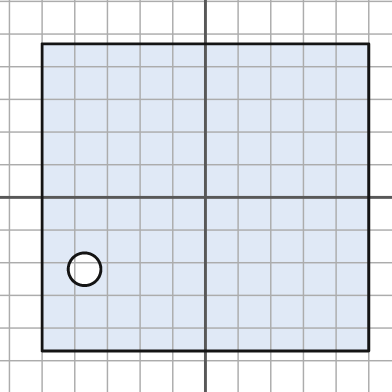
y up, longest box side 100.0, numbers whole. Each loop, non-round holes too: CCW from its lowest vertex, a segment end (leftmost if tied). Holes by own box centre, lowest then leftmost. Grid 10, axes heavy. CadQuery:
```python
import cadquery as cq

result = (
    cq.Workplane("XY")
    .moveTo(-50.0, -47.0)
    .lineTo(50.0, -47.0)
    .lineTo(50.0, 47.0)
    .lineTo(-50.0, 47.0)
    .close()
    .moveTo(-37.0, -22.0)
    .circle(5.0)
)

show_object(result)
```